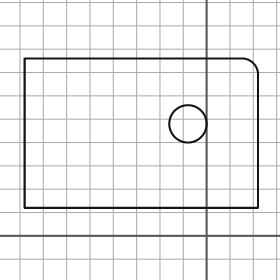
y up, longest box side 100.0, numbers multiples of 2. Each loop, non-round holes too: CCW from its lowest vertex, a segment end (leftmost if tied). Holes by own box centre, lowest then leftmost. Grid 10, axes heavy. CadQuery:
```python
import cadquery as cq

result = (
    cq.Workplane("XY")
    .moveTo(-78.0, 12.0)
    .lineTo(22.0, 12.0)
    .lineTo(22.0, 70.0)
    .threePointArc((20.0, 74.0), (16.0, 76.0))
    .lineTo(-78.0, 76.0)
    .close()
    .moveTo(-8.0, 48.0)
    .circle(8.0)
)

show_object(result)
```